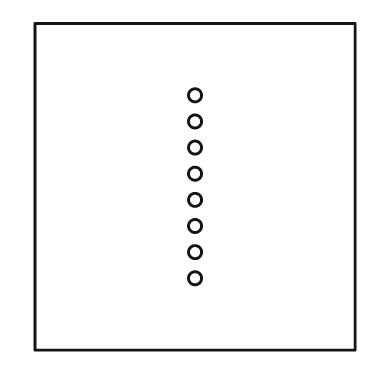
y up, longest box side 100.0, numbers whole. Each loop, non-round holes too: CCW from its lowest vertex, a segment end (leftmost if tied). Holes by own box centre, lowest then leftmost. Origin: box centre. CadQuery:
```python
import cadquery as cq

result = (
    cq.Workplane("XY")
    .moveTo(-49.0, -50.0)
    .lineTo(49.0, -50.0)
    .lineTo(49.0, 50.0)
    .lineTo(-49.0, 50.0)
    .close()
    .moveTo(0.0, -28.0)
    .circle(2.0)
    .moveTo(0.0, -20.0)
    .circle(2.0)
    .moveTo(0.0, -12.0)
    .circle(2.0)
    .moveTo(0.0, -4.0)
    .circle(2.0)
    .moveTo(0.0, 4.0)
    .circle(2.0)
    .moveTo(0.0, 12.0)
    .circle(2.0)
    .moveTo(0.0, 20.0)
    .circle(2.0)
    .moveTo(0.0, 28.0)
    .circle(2.0)
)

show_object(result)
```